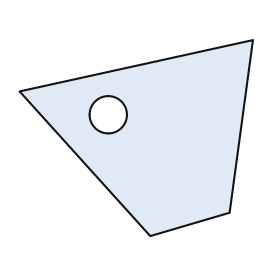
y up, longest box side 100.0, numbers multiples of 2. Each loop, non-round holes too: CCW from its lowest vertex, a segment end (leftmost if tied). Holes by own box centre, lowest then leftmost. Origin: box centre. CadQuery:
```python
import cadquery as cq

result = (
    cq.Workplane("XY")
    .moveTo(6.0, -42.0)
    .lineTo(40.0, -32.0)
    .lineTo(50.0, 42.0)
    .lineTo(-50.0, 20.0)
    .close()
    .moveTo(-12.0, 10.0)
    .circle(8.0)
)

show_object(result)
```